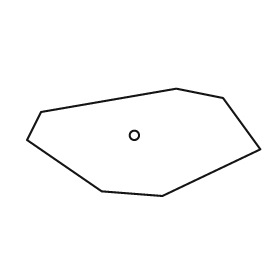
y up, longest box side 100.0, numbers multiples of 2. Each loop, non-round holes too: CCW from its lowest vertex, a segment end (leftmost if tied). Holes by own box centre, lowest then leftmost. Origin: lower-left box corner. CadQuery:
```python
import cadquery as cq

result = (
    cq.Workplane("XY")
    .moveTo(58.0, 0.0)
    .lineTo(100.0, 20.0)
    .lineTo(84.0, 42.0)
    .lineTo(64.0, 46.0)
    .lineTo(6.0, 36.0)
    .lineTo(0.0, 24.0)
    .lineTo(32.0, 2.0)
    .close()
    .moveTo(46.0, 26.0)
    .circle(2.0)
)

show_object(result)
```